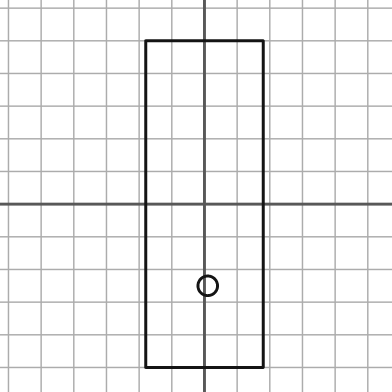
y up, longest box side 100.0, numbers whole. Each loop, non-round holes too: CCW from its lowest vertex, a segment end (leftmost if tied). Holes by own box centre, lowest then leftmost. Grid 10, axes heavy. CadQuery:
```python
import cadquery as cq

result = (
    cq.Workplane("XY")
    .moveTo(-18.0, -50.0)
    .lineTo(18.0, -50.0)
    .lineTo(18.0, 50.0)
    .lineTo(-18.0, 50.0)
    .close()
    .moveTo(1.0, -25.0)
    .circle(3.0)
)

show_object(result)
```